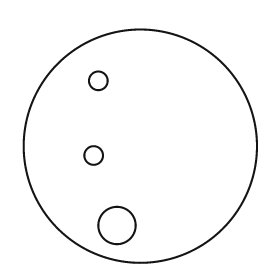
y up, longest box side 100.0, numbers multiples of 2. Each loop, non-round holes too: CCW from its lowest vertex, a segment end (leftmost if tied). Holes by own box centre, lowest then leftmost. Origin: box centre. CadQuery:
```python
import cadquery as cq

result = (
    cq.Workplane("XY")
    .moveTo(0.0, 0.0)
    .circle(50.0)
    .moveTo(-10.0, -34.0)
    .circle(8.0)
    .moveTo(-20.0, -4.0)
    .circle(4.0)
    .moveTo(-18.0, 28.0)
    .circle(4.0)
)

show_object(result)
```